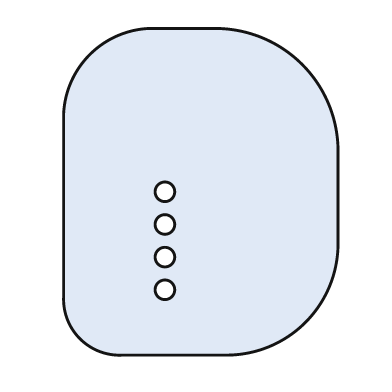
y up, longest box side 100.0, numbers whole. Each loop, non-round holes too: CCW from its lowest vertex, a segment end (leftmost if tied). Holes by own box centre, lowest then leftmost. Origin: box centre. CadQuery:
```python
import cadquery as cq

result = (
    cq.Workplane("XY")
    .moveTo(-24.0, -50.0)
    .lineTo(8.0, -50.0)
    .threePointArc((32.0, -40.0), (42.0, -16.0))
    .lineTo(42.0, 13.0)
    .threePointArc((31.0, 39.0), (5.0, 50.0))
    .lineTo(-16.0, 50.0)
    .threePointArc((-34.0, 42.0), (-42.0, 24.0))
    .lineTo(-42.0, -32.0)
    .threePointArc((-37.0, -45.0), (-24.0, -50.0))
    .close()
    .moveTo(-11.0, -30.0)
    .circle(3.0)
    .moveTo(-11.0, -20.0)
    .circle(3.0)
    .moveTo(-11.0, -10.0)
    .circle(3.0)
    .moveTo(-11.0, 0.0)
    .circle(3.0)
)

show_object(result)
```